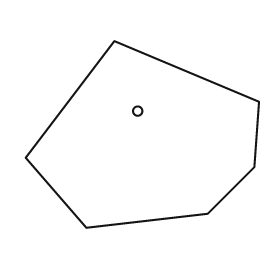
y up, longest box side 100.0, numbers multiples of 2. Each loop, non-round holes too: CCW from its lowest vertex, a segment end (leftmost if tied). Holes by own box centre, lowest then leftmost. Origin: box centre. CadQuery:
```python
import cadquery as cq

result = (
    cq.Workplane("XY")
    .moveTo(-24.0, -40.0)
    .lineTo(28.0, -34.0)
    .lineTo(48.0, -14.0)
    .lineTo(50.0, 14.0)
    .lineTo(-12.0, 40.0)
    .lineTo(-50.0, -10.0)
    .close()
    .moveTo(-2.0, 10.0)
    .circle(2.0)
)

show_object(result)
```